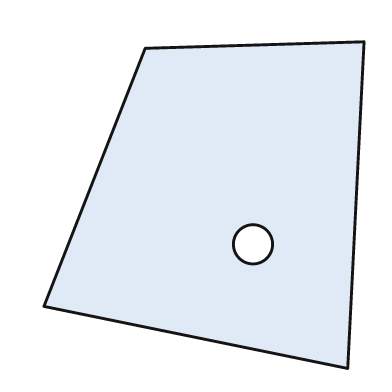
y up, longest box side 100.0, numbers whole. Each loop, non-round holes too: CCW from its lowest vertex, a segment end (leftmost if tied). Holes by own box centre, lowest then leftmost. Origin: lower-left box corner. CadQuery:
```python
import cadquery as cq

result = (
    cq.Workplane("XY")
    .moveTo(93.0, 0.0)
    .lineTo(98.0, 100.0)
    .lineTo(31.0, 98.0)
    .lineTo(0.0, 19.0)
    .close()
    .moveTo(64.0, 38.0)
    .circle(6.0)
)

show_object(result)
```